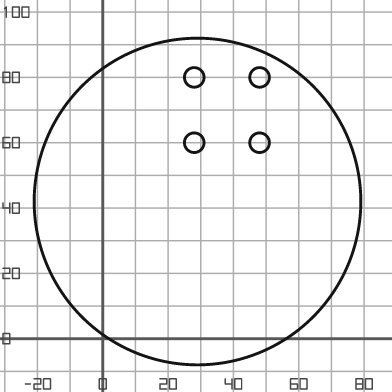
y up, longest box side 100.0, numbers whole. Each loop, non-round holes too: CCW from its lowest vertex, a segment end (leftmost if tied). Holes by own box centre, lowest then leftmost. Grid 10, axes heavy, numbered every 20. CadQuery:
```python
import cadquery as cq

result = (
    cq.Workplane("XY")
    .moveTo(29.0, 42.0)
    .circle(50.0)
    .moveTo(28.0, 60.0)
    .circle(3.0)
    .moveTo(48.0, 60.0)
    .circle(3.0)
    .moveTo(28.0, 80.0)
    .circle(3.0)
    .moveTo(48.0, 80.0)
    .circle(3.0)
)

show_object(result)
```